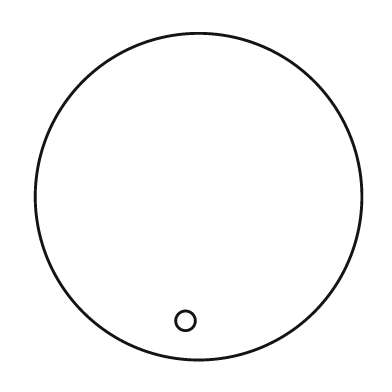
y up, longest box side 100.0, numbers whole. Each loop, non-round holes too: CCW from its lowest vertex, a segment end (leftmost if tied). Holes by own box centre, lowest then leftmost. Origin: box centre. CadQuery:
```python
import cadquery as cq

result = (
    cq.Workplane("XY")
    .moveTo(0.0, 0.0)
    .circle(50.0)
    .moveTo(-4.0, -38.0)
    .circle(3.0)
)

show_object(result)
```